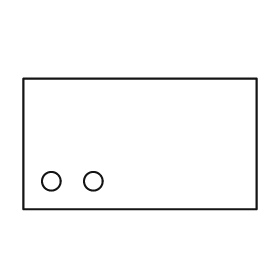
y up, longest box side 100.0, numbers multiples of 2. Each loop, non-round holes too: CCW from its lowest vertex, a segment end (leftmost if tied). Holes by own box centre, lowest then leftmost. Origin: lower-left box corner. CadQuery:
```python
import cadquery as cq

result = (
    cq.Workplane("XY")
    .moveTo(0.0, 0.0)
    .lineTo(100.0, 0.0)
    .lineTo(100.0, 56.0)
    .lineTo(0.0, 56.0)
    .close()
    .moveTo(12.0, 12.0)
    .circle(4.0)
    .moveTo(30.0, 12.0)
    .circle(4.0)
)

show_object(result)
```